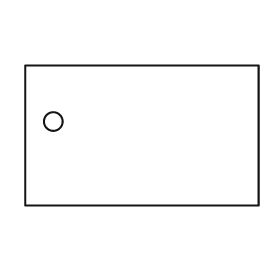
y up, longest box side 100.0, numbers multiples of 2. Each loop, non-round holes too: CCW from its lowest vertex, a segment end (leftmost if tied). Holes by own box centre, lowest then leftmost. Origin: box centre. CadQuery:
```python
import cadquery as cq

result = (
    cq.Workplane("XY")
    .moveTo(-50.0, -30.0)
    .lineTo(50.0, -30.0)
    .lineTo(50.0, 30.0)
    .lineTo(-50.0, 30.0)
    .close()
    .moveTo(-38.0, 6.0)
    .circle(4.0)
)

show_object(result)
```